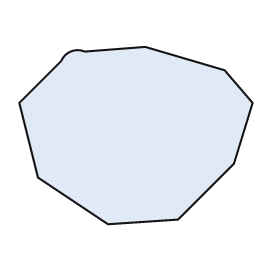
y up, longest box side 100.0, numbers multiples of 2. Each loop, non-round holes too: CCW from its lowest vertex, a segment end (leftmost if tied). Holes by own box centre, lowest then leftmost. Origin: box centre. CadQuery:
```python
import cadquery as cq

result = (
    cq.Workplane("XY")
    .moveTo(-12.0, -38.0)
    .lineTo(18.0, -36.0)
    .lineTo(42.0, -12.0)
    .lineTo(50.0, 14.0)
    .lineTo(38.0, 28.0)
    .lineTo(4.0, 38.0)
    .lineTo(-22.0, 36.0)
    .threePointArc((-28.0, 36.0), (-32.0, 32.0))
    .lineTo(-50.0, 14.0)
    .lineTo(-42.0, -18.0)
    .close()
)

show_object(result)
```